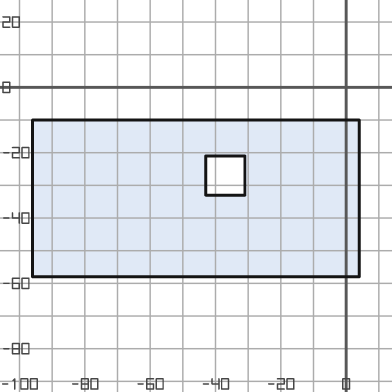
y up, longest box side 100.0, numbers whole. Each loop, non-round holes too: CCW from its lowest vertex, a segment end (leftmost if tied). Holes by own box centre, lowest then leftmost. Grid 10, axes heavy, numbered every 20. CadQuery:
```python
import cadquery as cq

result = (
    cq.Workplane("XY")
    .moveTo(-96.0, -58.0)
    .lineTo(4.0, -58.0)
    .lineTo(4.0, -10.0)
    .lineTo(-96.0, -10.0)
    .close()
    .moveTo(-43.0, -33.0)
    .lineTo(-31.0, -33.0)
    .lineTo(-31.0, -21.0)
    .lineTo(-43.0, -21.0)
    .close()
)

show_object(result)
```